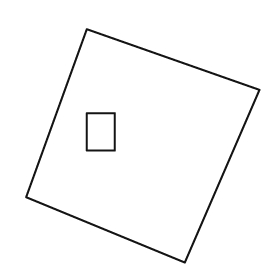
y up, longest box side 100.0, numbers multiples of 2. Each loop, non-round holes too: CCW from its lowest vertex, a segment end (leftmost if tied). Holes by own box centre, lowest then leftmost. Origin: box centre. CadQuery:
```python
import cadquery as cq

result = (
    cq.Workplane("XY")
    .moveTo(18.0, -50.0)
    .lineTo(50.0, 24.0)
    .lineTo(-24.0, 50.0)
    .lineTo(-50.0, -22.0)
    .close()
    .moveTo(-24.0, -2.0)
    .lineTo(-12.0, -2.0)
    .lineTo(-12.0, 14.0)
    .lineTo(-24.0, 14.0)
    .close()
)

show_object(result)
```